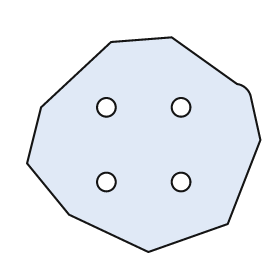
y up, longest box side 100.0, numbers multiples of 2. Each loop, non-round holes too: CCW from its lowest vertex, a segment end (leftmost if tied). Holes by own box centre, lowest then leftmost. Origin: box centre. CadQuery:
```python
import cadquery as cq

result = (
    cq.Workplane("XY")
    .moveTo(2.0, -46.0)
    .lineTo(36.0, -34.0)
    .lineTo(50.0, 2.0)
    .lineTo(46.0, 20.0)
    .threePointArc((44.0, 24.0), (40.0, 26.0))
    .lineTo(12.0, 46.0)
    .lineTo(-14.0, 44.0)
    .lineTo(-44.0, 16.0)
    .lineTo(-50.0, -8.0)
    .lineTo(-32.0, -30.0)
    .close()
    .moveTo(-16.0, -16.0)
    .circle(4.0)
    .moveTo(16.0, -16.0)
    .circle(4.0)
    .moveTo(-16.0, 16.0)
    .circle(4.0)
    .moveTo(16.0, 16.0)
    .circle(4.0)
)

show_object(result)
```